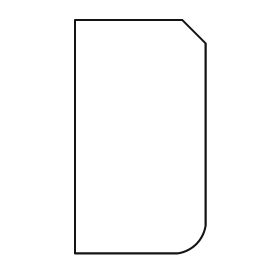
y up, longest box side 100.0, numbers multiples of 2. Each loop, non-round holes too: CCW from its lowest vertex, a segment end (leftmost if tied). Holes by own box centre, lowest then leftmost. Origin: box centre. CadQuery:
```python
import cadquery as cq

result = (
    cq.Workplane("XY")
    .moveTo(-28.0, -50.0)
    .lineTo(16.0, -50.0)
    .threePointArc((24.0, -46.0), (28.0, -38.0))
    .lineTo(28.0, 40.0)
    .lineTo(18.0, 50.0)
    .lineTo(-28.0, 50.0)
    .close()
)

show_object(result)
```